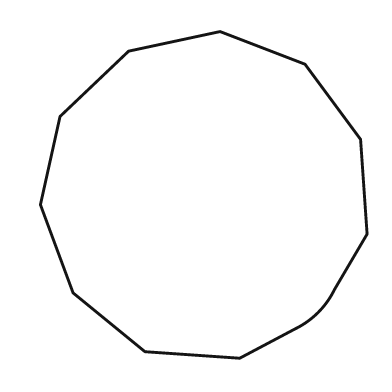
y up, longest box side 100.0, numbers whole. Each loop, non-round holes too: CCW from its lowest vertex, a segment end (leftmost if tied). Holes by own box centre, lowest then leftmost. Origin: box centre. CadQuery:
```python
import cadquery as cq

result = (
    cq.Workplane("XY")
    .moveTo(11.0, -50.0)
    .lineTo(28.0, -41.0)
    .threePointArc((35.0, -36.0), (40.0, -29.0))
    .lineTo(50.0, -12.0)
    .lineTo(48.0, 17.0)
    .lineTo(31.0, 40.0)
    .lineTo(5.0, 50.0)
    .lineTo(-23.0, 44.0)
    .lineTo(-44.0, 24.0)
    .lineTo(-50.0, -3.0)
    .lineTo(-40.0, -30.0)
    .lineTo(-18.0, -48.0)
    .close()
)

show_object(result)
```